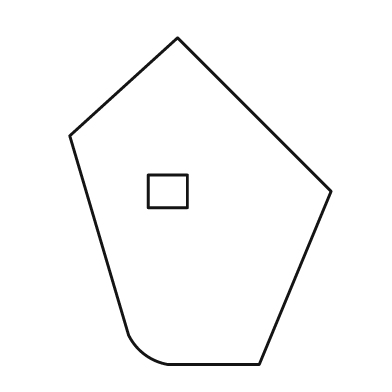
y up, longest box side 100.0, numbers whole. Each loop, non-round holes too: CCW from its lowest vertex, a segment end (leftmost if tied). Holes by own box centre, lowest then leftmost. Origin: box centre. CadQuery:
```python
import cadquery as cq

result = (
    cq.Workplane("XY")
    .moveTo(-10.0, -50.0)
    .lineTo(18.0, -50.0)
    .lineTo(40.0, 3.0)
    .lineTo(-7.0, 50.0)
    .lineTo(-40.0, 20.0)
    .lineTo(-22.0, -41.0)
    .threePointArc((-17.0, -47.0), (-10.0, -50.0))
    .close()
    .moveTo(-16.0, -2.0)
    .lineTo(-4.0, -2.0)
    .lineTo(-4.0, 8.0)
    .lineTo(-16.0, 8.0)
    .close()
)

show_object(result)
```